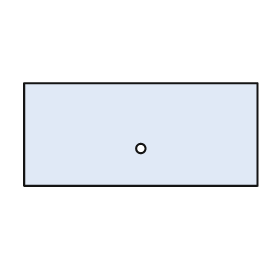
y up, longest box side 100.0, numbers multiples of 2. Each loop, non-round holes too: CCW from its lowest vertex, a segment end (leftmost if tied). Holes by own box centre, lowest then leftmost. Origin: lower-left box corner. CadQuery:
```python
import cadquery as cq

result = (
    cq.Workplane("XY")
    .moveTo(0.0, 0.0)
    .lineTo(100.0, 0.0)
    .lineTo(100.0, 44.0)
    .lineTo(0.0, 44.0)
    .close()
    .moveTo(50.0, 16.0)
    .circle(2.0)
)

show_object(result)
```